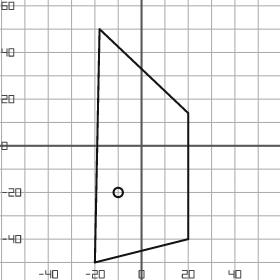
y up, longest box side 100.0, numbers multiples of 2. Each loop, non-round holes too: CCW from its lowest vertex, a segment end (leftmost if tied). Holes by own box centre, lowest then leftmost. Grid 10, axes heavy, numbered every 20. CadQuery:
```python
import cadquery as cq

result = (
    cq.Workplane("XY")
    .moveTo(-20.0, -50.0)
    .lineTo(20.0, -40.0)
    .lineTo(20.0, 14.0)
    .lineTo(-18.0, 50.0)
    .close()
    .moveTo(-10.0, -20.0)
    .circle(2.0)
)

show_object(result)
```